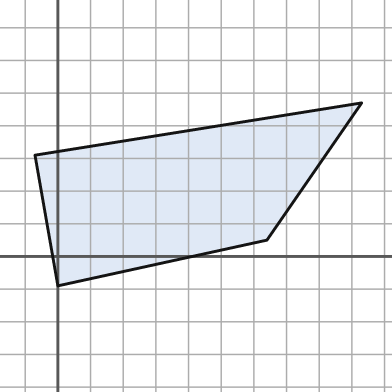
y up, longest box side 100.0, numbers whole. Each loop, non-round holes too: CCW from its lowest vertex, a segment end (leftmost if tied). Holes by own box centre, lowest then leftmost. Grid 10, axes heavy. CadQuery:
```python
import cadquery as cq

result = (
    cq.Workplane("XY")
    .moveTo(0.0, -9.0)
    .lineTo(64.0, 5.0)
    .lineTo(93.0, 47.0)
    .lineTo(-7.0, 31.0)
    .close()
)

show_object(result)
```